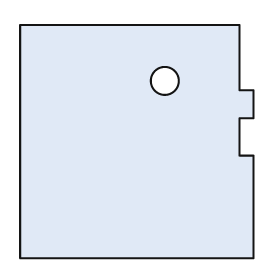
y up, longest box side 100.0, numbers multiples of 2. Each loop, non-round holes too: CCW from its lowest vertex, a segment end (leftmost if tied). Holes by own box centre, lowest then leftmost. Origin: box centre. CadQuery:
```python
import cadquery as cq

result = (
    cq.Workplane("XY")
    .moveTo(-50.0, -50.0)
    .lineTo(50.0, -50.0)
    .lineTo(50.0, -6.0)
    .lineTo(44.0, -6.0)
    .lineTo(44.0, 10.0)
    .lineTo(50.0, 10.0)
    .lineTo(50.0, 22.0)
    .lineTo(44.0, 22.0)
    .lineTo(44.0, 50.0)
    .lineTo(-50.0, 50.0)
    .close()
    .moveTo(12.0, 26.0)
    .circle(6.0)
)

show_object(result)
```